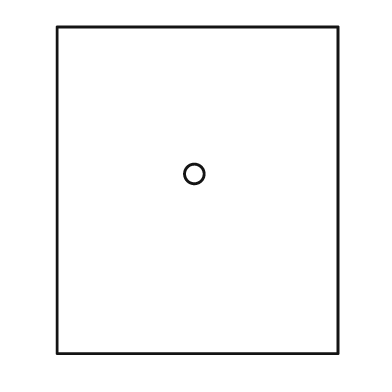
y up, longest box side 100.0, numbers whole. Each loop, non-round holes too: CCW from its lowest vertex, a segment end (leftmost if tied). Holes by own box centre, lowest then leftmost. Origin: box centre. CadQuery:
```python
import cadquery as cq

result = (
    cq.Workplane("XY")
    .moveTo(-43.0, -50.0)
    .lineTo(43.0, -50.0)
    .lineTo(43.0, 50.0)
    .lineTo(-43.0, 50.0)
    .close()
    .moveTo(-1.0, 5.0)
    .circle(3.0)
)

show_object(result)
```